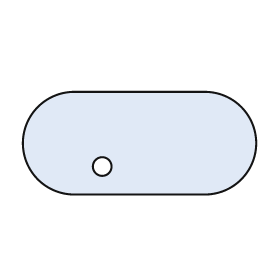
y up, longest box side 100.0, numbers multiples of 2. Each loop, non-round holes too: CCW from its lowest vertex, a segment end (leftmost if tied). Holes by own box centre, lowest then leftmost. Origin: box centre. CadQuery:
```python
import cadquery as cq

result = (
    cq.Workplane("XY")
    .moveTo(-28.0, -22.0)
    .lineTo(28.0, -22.0)
    .threePointArc((50.0, 0.0), (28.0, 22.0))
    .lineTo(-28.0, 22.0)
    .threePointArc((-50.0, 0.0), (-28.0, -22.0))
    .close()
    .moveTo(-16.0, -10.0)
    .circle(4.0)
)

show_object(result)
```